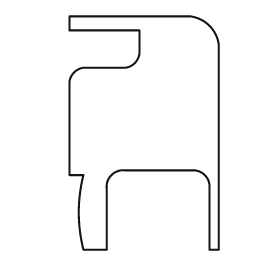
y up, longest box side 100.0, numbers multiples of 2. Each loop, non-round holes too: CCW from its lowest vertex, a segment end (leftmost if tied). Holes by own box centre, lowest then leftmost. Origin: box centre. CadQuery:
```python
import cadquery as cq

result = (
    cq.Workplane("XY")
    .moveTo(-26.0, -50.0)
    .lineTo(-16.0, -50.0)
    .lineTo(-16.0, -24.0)
    .threePointArc((-14.0, -18.0), (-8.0, -16.0))
    .lineTo(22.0, -16.0)
    .threePointArc((26.0, -18.0), (28.0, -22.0))
    .lineTo(28.0, -50.0)
    .lineTo(32.0, -50.0)
    .lineTo(32.0, 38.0)
    .threePointArc((28.0, 46.0), (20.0, 50.0))
    .lineTo(-32.0, 50.0)
    .lineTo(-32.0, 44.0)
    .lineTo(-2.0, 44.0)
    .lineTo(-2.0, 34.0)
    .threePointArc((-4.0, 30.0), (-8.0, 28.0))
    .lineTo(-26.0, 28.0)
    .threePointArc((-30.0, 26.0), (-32.0, 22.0))
    .lineTo(-32.0, -18.0)
    .lineTo(-26.0, -18.0)
    .threePointArc((-28.0, -34.0), (-26.0, -50.0))
    .close()
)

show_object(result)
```